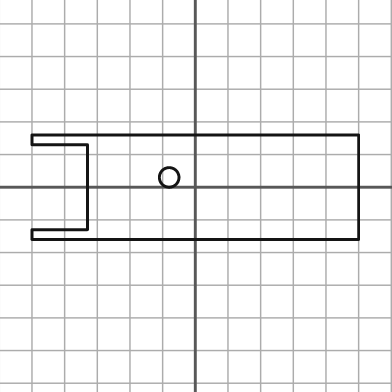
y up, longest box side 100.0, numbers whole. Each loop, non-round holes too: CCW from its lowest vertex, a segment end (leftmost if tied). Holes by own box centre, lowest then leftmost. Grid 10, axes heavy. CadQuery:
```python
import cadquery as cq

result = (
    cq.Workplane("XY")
    .moveTo(-50.0, -16.0)
    .lineTo(50.0, -16.0)
    .lineTo(50.0, 16.0)
    .lineTo(-50.0, 16.0)
    .lineTo(-50.0, 13.0)
    .lineTo(-33.0, 13.0)
    .lineTo(-33.0, -13.0)
    .lineTo(-50.0, -13.0)
    .close()
    .moveTo(-8.0, 3.0)
    .circle(3.0)
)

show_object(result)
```